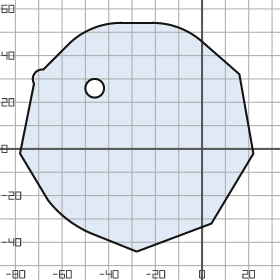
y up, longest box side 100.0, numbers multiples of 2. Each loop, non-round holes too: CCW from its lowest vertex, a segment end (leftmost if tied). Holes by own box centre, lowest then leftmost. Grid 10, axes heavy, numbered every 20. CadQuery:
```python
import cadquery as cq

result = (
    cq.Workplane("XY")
    .moveTo(-28.0, -44.0)
    .lineTo(4.0, -32.0)
    .lineTo(22.0, -2.0)
    .lineTo(16.0, 32.0)
    .lineTo(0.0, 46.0)
    .threePointArc((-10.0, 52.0), (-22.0, 54.0))
    .lineTo(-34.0, 54.0)
    .threePointArc((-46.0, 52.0), (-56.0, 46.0))
    .lineTo(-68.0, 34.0)
    .threePointArc((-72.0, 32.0), (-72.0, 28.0))
    .lineTo(-78.0, -2.0)
    .lineTo(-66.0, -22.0)
    .threePointArc((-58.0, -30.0), (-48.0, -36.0))
    .close()
    .moveTo(-46.0, 26.0)
    .circle(4.0)
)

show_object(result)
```